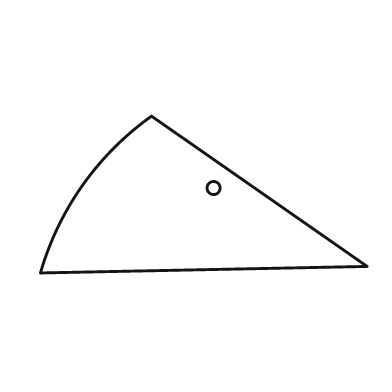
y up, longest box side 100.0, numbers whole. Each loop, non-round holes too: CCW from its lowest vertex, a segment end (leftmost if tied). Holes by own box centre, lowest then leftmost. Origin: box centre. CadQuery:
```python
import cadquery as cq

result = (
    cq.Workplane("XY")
    .moveTo(-50.0, -24.0)
    .lineTo(50.0, -22.0)
    .lineTo(-16.0, 24.0)
    .threePointArc((-37.0, 3.0), (-50.0, -24.0))
    .close()
    .moveTo(3.0, 2.0)
    .circle(2.0)
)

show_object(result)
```